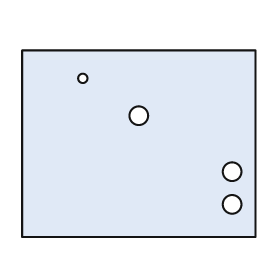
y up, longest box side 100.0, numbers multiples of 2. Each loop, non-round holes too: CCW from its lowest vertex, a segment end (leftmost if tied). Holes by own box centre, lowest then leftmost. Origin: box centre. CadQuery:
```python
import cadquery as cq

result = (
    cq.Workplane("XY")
    .moveTo(-50.0, -40.0)
    .lineTo(50.0, -40.0)
    .lineTo(50.0, 40.0)
    .lineTo(-50.0, 40.0)
    .close()
    .moveTo(40.0, -26.0)
    .circle(4.0)
    .moveTo(40.0, -12.0)
    .circle(4.0)
    .moveTo(0.0, 12.0)
    .circle(4.0)
    .moveTo(-24.0, 28.0)
    .circle(2.0)
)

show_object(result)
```